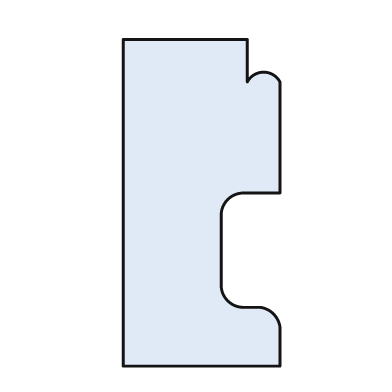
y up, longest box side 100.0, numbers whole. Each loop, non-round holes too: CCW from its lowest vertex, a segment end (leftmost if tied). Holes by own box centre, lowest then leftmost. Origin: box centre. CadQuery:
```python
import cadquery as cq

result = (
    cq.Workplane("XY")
    .moveTo(-24.0, -50.0)
    .lineTo(24.0, -50.0)
    .lineTo(24.0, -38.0)
    .threePointArc((22.0, -34.0), (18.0, -32.0))
    .lineTo(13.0, -32.0)
    .threePointArc((8.0, -30.0), (6.0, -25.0))
    .lineTo(6.0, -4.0)
    .threePointArc((8.0, 1.0), (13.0, 3.0))
    .lineTo(24.0, 3.0)
    .lineTo(24.0, 37.0)
    .threePointArc((19.0, 40.0), (14.0, 37.0))
    .lineTo(14.0, 50.0)
    .lineTo(-24.0, 50.0)
    .close()
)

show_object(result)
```